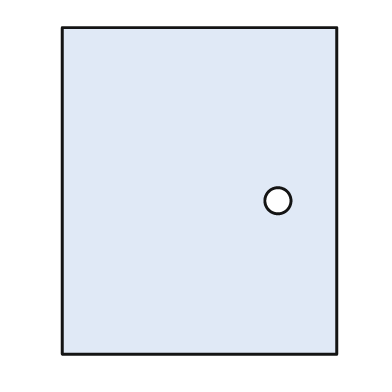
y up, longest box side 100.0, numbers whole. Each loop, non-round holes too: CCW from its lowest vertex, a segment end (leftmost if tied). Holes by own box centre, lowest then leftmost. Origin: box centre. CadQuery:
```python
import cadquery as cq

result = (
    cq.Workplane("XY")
    .moveTo(-42.0, -50.0)
    .lineTo(42.0, -50.0)
    .lineTo(42.0, 50.0)
    .lineTo(-42.0, 50.0)
    .close()
    .moveTo(24.0, -3.0)
    .circle(4.0)
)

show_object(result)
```